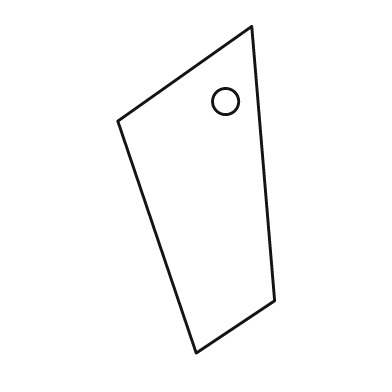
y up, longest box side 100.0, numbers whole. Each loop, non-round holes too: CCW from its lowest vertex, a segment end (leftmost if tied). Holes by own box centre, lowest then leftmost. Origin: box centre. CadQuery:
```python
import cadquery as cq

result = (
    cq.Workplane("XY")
    .moveTo(0.0, -50.0)
    .lineTo(24.0, -34.0)
    .lineTo(17.0, 50.0)
    .lineTo(-24.0, 21.0)
    .close()
    .moveTo(9.0, 27.0)
    .circle(4.0)
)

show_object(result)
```